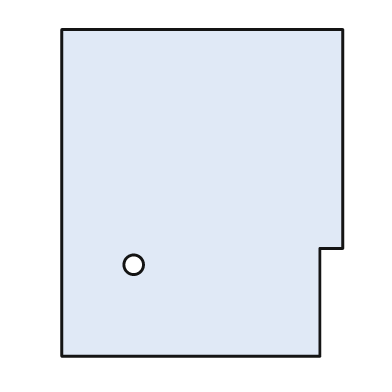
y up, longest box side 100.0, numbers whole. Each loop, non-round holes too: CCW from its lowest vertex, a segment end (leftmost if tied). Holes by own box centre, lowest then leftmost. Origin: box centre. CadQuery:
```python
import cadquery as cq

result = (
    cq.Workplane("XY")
    .moveTo(-43.0, -50.0)
    .lineTo(36.0, -50.0)
    .lineTo(36.0, -17.0)
    .lineTo(43.0, -17.0)
    .lineTo(43.0, 50.0)
    .lineTo(-43.0, 50.0)
    .close()
    .moveTo(-21.0, -22.0)
    .circle(3.0)
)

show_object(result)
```